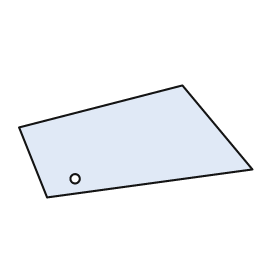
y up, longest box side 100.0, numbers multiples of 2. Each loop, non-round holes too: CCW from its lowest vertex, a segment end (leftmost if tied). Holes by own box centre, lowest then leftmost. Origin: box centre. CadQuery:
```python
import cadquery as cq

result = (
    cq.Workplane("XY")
    .moveTo(-38.0, -24.0)
    .lineTo(50.0, -12.0)
    .lineTo(20.0, 24.0)
    .lineTo(-50.0, 6.0)
    .close()
    .moveTo(-26.0, -16.0)
    .circle(2.0)
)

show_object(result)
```